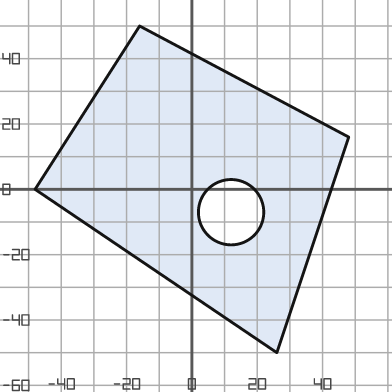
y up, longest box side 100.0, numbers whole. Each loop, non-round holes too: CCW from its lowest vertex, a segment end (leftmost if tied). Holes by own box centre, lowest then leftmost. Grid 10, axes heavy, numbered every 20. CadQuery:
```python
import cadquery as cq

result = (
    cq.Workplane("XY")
    .moveTo(26.0, -50.0)
    .lineTo(48.0, 16.0)
    .lineTo(-16.0, 50.0)
    .lineTo(-48.0, 0.0)
    .close()
    .moveTo(12.0, -7.0)
    .circle(10.0)
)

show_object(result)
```